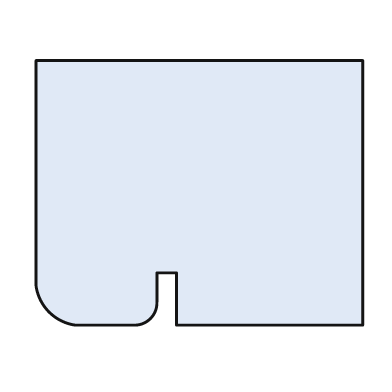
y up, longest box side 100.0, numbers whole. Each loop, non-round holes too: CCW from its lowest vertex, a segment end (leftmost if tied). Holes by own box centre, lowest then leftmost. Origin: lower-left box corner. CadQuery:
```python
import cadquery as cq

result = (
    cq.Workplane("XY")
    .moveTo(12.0, 0.0)
    .lineTo(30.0, 0.0)
    .threePointArc((35.0, 2.0), (37.0, 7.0))
    .lineTo(37.0, 16.0)
    .lineTo(43.0, 16.0)
    .lineTo(43.0, 0.0)
    .lineTo(100.0, 0.0)
    .lineTo(100.0, 81.0)
    .lineTo(0.0, 81.0)
    .lineTo(0.0, 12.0)
    .threePointArc((4.0, 4.0), (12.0, 0.0))
    .close()
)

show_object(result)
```